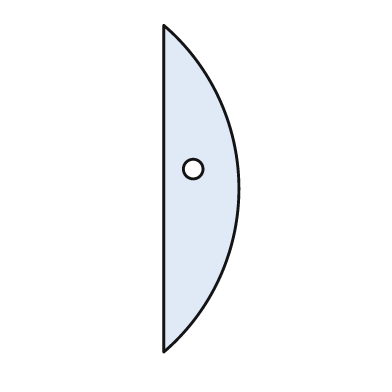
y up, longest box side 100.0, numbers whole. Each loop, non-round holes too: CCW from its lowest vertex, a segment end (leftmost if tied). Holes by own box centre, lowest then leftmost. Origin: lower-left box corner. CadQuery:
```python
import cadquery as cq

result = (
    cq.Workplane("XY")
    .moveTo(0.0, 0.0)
    .threePointArc((23.0, 50.0), (0.0, 100.0))
    .close()
    .moveTo(9.0, 56.0)
    .circle(3.0)
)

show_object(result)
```